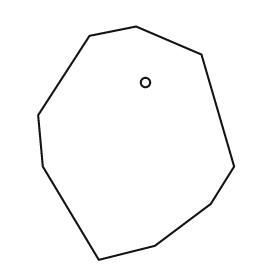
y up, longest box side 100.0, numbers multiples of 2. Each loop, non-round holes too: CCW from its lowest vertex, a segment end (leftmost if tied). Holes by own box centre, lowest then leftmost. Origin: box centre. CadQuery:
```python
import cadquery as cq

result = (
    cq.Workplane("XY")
    .moveTo(-16.0, -50.0)
    .lineTo(8.0, -44.0)
    .lineTo(32.0, -26.0)
    .lineTo(42.0, -10.0)
    .lineTo(28.0, 38.0)
    .lineTo(0.0, 50.0)
    .lineTo(-20.0, 46.0)
    .lineTo(-42.0, 12.0)
    .lineTo(-40.0, -10.0)
    .close()
    .moveTo(4.0, 26.0)
    .circle(2.0)
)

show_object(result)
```